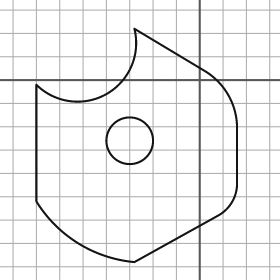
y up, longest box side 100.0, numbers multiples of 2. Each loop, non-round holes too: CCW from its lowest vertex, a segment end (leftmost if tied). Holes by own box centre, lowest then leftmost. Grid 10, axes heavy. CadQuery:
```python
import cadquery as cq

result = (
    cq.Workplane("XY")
    .moveTo(-28.0, -78.0)
    .lineTo(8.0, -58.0)
    .threePointArc((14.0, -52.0), (16.0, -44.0))
    .lineTo(16.0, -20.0)
    .threePointArc((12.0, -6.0), (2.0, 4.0))
    .lineTo(-28.0, 22.0)
    .threePointArc((-40.0, -6.0), (-70.0, -2.0))
    .lineTo(-70.0, -52.0)
    .threePointArc((-52.0, -70.0), (-28.0, -78.0))
    .close()
    .moveTo(-30.0, -26.0)
    .circle(10.0)
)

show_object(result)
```